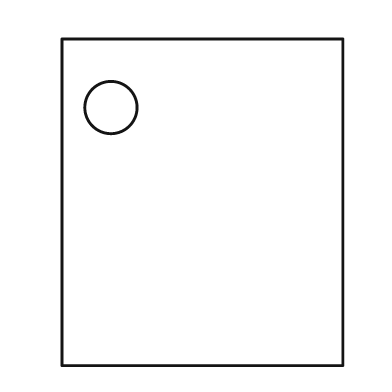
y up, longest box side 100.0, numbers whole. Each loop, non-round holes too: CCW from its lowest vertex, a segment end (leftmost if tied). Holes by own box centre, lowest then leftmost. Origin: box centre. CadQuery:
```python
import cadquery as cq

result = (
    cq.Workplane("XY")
    .moveTo(-43.0, -50.0)
    .lineTo(43.0, -50.0)
    .lineTo(43.0, 50.0)
    .lineTo(-43.0, 50.0)
    .close()
    .moveTo(-28.0, 29.0)
    .circle(8.0)
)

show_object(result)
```